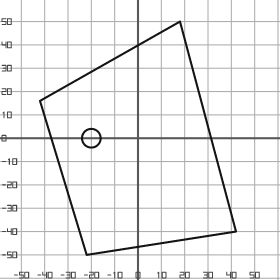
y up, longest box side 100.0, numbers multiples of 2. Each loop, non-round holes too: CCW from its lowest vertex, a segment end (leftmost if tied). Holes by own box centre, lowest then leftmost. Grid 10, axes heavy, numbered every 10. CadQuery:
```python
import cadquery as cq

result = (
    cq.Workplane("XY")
    .moveTo(-22.0, -50.0)
    .lineTo(42.0, -40.0)
    .lineTo(18.0, 50.0)
    .lineTo(-42.0, 16.0)
    .close()
    .moveTo(-20.0, 0.0)
    .circle(4.0)
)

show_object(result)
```